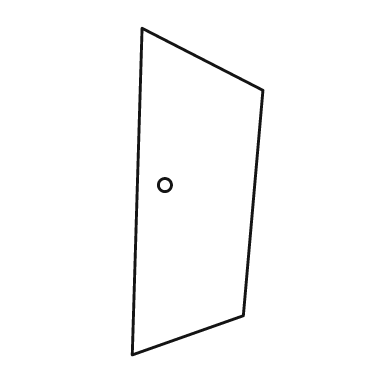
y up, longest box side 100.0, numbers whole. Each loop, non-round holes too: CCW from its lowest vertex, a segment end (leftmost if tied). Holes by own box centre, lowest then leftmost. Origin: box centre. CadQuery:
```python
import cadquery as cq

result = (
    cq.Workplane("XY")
    .moveTo(-20.0, -50.0)
    .lineTo(14.0, -38.0)
    .lineTo(20.0, 31.0)
    .lineTo(-17.0, 50.0)
    .close()
    .moveTo(-10.0, 2.0)
    .circle(2.0)
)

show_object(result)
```